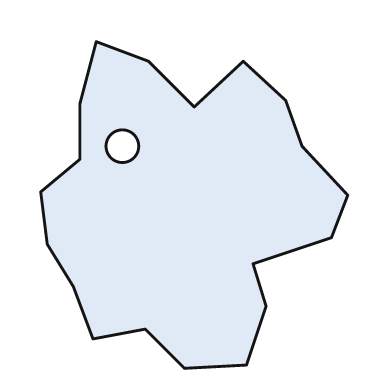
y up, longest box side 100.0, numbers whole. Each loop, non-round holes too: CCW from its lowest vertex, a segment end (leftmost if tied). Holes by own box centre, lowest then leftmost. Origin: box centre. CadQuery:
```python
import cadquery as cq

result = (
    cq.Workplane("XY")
    .moveTo(-3.0, -50.0)
    .lineTo(16.0, -49.0)
    .lineTo(22.0, -31.0)
    .lineTo(18.0, -18.0)
    .lineTo(42.0, -10.0)
    .lineTo(47.0, 3.0)
    .lineTo(33.0, 18.0)
    .lineTo(28.0, 32.0)
    .lineTo(15.0, 44.0)
    .lineTo(0.0, 30.0)
    .lineTo(-14.0, 44.0)
    .lineTo(-30.0, 50.0)
    .lineTo(-35.0, 31.0)
    .lineTo(-35.0, 14.0)
    .lineTo(-47.0, 4.0)
    .lineTo(-45.0, -12.0)
    .lineTo(-37.0, -25.0)
    .lineTo(-31.0, -41.0)
    .lineTo(-15.0, -38.0)
    .close()
    .moveTo(-22.0, 18.0)
    .circle(5.0)
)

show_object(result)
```